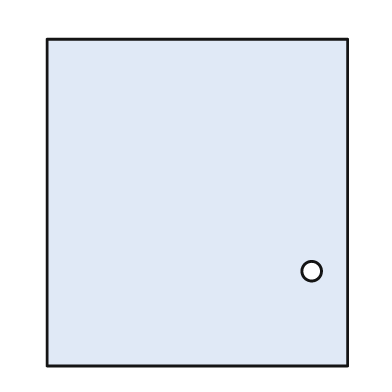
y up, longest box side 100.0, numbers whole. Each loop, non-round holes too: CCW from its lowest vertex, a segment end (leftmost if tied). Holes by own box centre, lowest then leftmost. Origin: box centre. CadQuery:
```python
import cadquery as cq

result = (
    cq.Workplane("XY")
    .moveTo(-46.0, -50.0)
    .lineTo(46.0, -50.0)
    .lineTo(46.0, 50.0)
    .lineTo(-46.0, 50.0)
    .close()
    .moveTo(35.0, -21.0)
    .circle(3.0)
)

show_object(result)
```